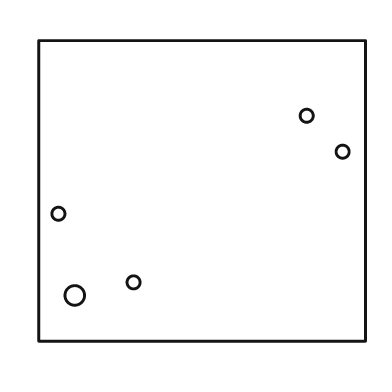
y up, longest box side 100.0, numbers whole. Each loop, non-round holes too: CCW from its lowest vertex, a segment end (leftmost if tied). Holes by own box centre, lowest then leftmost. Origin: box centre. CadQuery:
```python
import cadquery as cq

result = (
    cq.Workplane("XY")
    .moveTo(-50.0, -46.0)
    .lineTo(50.0, -46.0)
    .lineTo(50.0, 46.0)
    .lineTo(-50.0, 46.0)
    .close()
    .moveTo(-39.0, -32.0)
    .circle(3.0)
    .moveTo(-21.0, -28.0)
    .circle(2.0)
    .moveTo(-44.0, -7.0)
    .circle(2.0)
    .moveTo(43.0, 12.0)
    .circle(2.0)
    .moveTo(32.0, 23.0)
    .circle(2.0)
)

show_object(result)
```